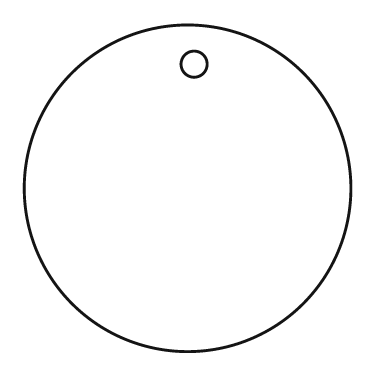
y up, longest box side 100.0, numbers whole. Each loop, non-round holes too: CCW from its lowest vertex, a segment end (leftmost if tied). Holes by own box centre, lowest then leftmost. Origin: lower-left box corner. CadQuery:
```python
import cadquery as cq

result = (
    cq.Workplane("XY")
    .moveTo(50.0, 50.0)
    .circle(50.0)
    .moveTo(52.0, 88.0)
    .circle(4.0)
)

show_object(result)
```